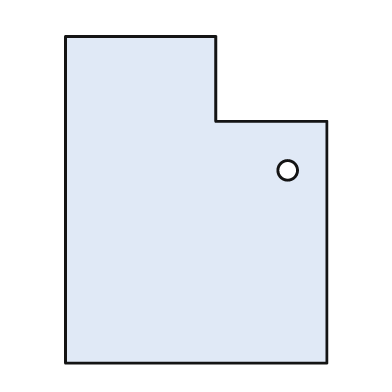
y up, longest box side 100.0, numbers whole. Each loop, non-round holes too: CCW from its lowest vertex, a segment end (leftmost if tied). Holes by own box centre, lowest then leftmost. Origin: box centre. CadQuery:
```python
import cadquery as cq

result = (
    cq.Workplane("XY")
    .moveTo(-40.0, -50.0)
    .lineTo(40.0, -50.0)
    .lineTo(40.0, 24.0)
    .lineTo(6.0, 24.0)
    .lineTo(6.0, 50.0)
    .lineTo(-40.0, 50.0)
    .close()
    .moveTo(28.0, 9.0)
    .circle(3.0)
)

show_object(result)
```